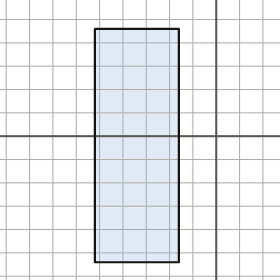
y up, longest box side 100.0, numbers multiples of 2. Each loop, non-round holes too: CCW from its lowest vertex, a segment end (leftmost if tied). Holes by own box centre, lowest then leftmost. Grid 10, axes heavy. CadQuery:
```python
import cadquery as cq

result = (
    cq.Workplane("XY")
    .moveTo(-52.0, -54.0)
    .lineTo(-16.0, -54.0)
    .lineTo(-16.0, 46.0)
    .lineTo(-52.0, 46.0)
    .close()
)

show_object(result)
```